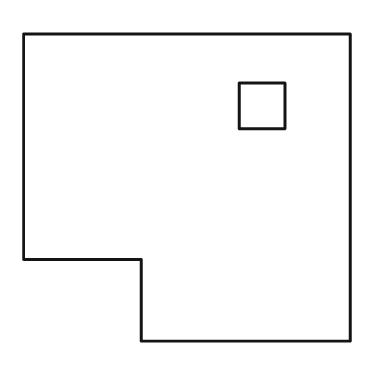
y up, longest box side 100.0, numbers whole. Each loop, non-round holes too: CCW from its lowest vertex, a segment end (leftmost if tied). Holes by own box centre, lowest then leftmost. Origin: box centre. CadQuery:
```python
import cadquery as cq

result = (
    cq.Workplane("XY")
    .moveTo(-14.0, -47.0)
    .lineTo(50.0, -47.0)
    .lineTo(50.0, 47.0)
    .lineTo(-50.0, 47.0)
    .lineTo(-50.0, -22.0)
    .lineTo(-14.0, -22.0)
    .close()
    .moveTo(16.0, 18.0)
    .lineTo(30.0, 18.0)
    .lineTo(30.0, 32.0)
    .lineTo(16.0, 32.0)
    .close()
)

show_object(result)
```